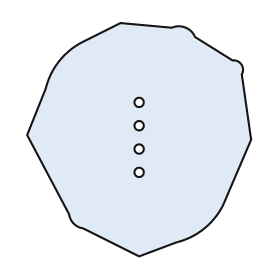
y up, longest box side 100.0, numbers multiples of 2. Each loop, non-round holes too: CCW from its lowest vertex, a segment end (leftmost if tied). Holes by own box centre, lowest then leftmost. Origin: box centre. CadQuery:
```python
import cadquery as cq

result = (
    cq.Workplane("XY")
    .moveTo(0.0, -50.0)
    .lineTo(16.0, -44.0)
    .threePointArc((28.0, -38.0), (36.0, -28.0))
    .lineTo(48.0, 0.0)
    .lineTo(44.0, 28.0)
    .threePointArc((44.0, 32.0), (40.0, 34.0))
    .lineTo(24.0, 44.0)
    .threePointArc((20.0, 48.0), (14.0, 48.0))
    .lineTo(-8.0, 50.0)
    .lineTo(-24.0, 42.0)
    .threePointArc((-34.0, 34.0), (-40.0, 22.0))
    .lineTo(-48.0, 2.0)
    .lineTo(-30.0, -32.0)
    .threePointArc((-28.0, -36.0), (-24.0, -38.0))
    .close()
    .moveTo(0.0, -14.0)
    .circle(2.0)
    .moveTo(0.0, -4.0)
    .circle(2.0)
    .moveTo(0.0, 6.0)
    .circle(2.0)
    .moveTo(0.0, 16.0)
    .circle(2.0)
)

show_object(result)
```